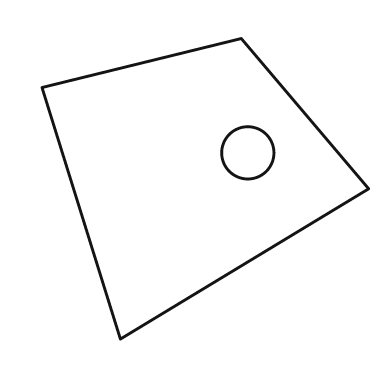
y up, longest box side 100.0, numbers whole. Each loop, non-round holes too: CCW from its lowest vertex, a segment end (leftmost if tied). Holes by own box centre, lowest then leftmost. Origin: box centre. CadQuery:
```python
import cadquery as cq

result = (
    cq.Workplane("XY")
    .moveTo(-26.0, -46.0)
    .lineTo(50.0, 0.0)
    .lineTo(11.0, 46.0)
    .lineTo(-50.0, 31.0)
    .close()
    .moveTo(13.0, 11.0)
    .circle(8.0)
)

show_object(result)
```